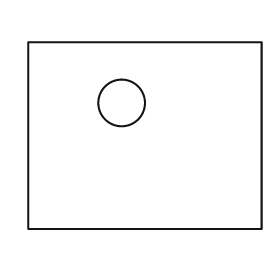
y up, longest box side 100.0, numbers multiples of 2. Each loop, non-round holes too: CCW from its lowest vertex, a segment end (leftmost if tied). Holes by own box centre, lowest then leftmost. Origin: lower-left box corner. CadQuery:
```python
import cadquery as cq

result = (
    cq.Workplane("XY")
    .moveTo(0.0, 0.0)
    .lineTo(100.0, 0.0)
    .lineTo(100.0, 80.0)
    .lineTo(0.0, 80.0)
    .close()
    .moveTo(40.0, 54.0)
    .circle(10.0)
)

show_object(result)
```